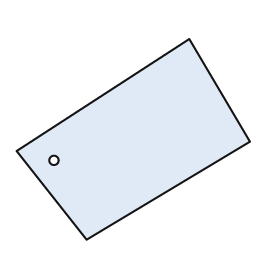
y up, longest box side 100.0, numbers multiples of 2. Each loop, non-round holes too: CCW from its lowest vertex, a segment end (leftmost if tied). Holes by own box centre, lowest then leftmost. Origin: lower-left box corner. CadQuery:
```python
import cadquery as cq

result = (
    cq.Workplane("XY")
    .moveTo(30.0, 0.0)
    .lineTo(100.0, 42.0)
    .lineTo(74.0, 86.0)
    .lineTo(0.0, 38.0)
    .close()
    .moveTo(16.0, 34.0)
    .circle(2.0)
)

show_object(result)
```